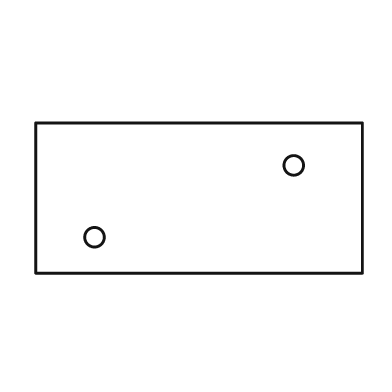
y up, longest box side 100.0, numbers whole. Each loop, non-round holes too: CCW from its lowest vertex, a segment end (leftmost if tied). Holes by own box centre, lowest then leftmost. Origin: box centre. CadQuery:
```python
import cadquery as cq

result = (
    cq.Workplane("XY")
    .moveTo(-50.0, -23.0)
    .lineTo(50.0, -23.0)
    .lineTo(50.0, 23.0)
    .lineTo(-50.0, 23.0)
    .close()
    .moveTo(-32.0, -12.0)
    .circle(3.0)
    .moveTo(29.0, 10.0)
    .circle(3.0)
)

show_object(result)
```